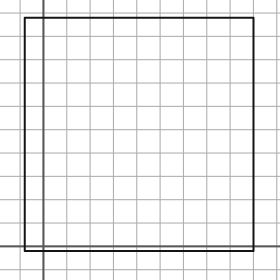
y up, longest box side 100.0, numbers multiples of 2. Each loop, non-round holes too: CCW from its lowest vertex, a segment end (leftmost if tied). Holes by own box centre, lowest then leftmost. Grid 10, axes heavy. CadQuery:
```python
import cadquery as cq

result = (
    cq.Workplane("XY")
    .moveTo(-8.0, -2.0)
    .lineTo(90.0, -2.0)
    .lineTo(90.0, 98.0)
    .lineTo(-8.0, 98.0)
    .close()
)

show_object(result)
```